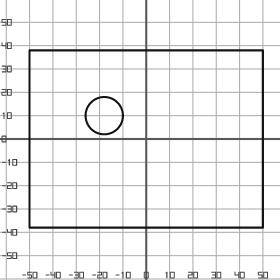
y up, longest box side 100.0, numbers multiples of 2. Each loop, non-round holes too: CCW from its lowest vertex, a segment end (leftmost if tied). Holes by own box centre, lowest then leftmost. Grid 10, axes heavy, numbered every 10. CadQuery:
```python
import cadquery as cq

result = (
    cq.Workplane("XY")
    .moveTo(-50.0, -38.0)
    .lineTo(50.0, -38.0)
    .lineTo(50.0, 38.0)
    .lineTo(-50.0, 38.0)
    .close()
    .moveTo(-18.0, 10.0)
    .circle(8.0)
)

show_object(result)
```